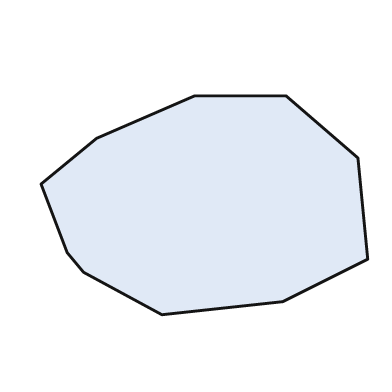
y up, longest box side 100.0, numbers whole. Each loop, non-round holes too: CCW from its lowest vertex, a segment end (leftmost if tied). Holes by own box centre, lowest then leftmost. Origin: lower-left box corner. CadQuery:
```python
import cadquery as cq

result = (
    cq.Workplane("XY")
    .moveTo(37.0, 0.0)
    .lineTo(74.0, 4.0)
    .lineTo(100.0, 17.0)
    .lineTo(97.0, 48.0)
    .lineTo(75.0, 67.0)
    .lineTo(47.0, 67.0)
    .lineTo(17.0, 54.0)
    .lineTo(0.0, 40.0)
    .lineTo(8.0, 19.0)
    .lineTo(13.0, 13.0)
    .close()
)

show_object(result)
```